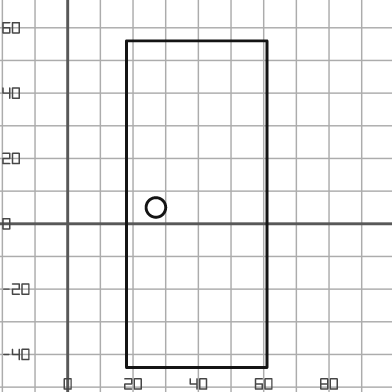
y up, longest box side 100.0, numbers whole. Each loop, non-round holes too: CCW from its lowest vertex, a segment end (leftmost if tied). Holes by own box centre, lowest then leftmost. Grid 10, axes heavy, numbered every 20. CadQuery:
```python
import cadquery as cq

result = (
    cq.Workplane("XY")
    .moveTo(18.0, -44.0)
    .lineTo(61.0, -44.0)
    .lineTo(61.0, 56.0)
    .lineTo(18.0, 56.0)
    .close()
    .moveTo(27.0, 5.0)
    .circle(3.0)
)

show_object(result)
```